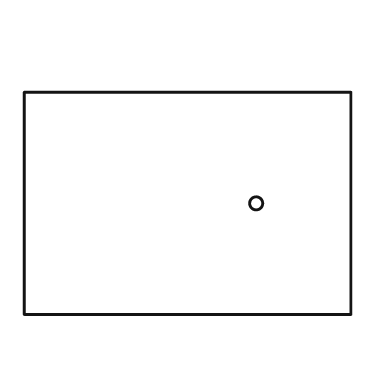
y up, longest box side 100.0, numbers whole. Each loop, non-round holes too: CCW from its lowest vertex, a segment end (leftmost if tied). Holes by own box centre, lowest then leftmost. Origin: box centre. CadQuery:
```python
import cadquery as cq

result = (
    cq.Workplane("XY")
    .moveTo(-50.0, -34.0)
    .lineTo(50.0, -34.0)
    .lineTo(50.0, 34.0)
    .lineTo(-50.0, 34.0)
    .close()
    .moveTo(21.0, 0.0)
    .circle(2.0)
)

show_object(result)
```